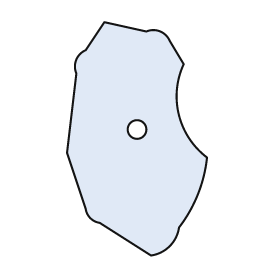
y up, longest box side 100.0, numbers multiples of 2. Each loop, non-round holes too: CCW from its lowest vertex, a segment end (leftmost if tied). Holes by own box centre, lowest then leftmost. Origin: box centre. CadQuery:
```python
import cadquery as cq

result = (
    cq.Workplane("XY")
    .moveTo(6.0, -50.0)
    .threePointArc((14.0, -46.0), (18.0, -38.0))
    .threePointArc((26.0, -24.0), (30.0, -8.0))
    .threePointArc((18.0, 10.0), (20.0, 32.0))
    .lineTo(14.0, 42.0)
    .threePointArc((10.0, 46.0), (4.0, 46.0))
    .lineTo(-14.0, 50.0)
    .lineTo(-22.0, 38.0)
    .threePointArc((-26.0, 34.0), (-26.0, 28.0))
    .lineTo(-30.0, -6.0)
    .lineTo(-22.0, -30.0)
    .threePointArc((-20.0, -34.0), (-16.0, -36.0))
    .close()
    .moveTo(0.0, 4.0)
    .circle(4.0)
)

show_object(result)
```